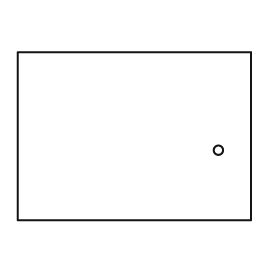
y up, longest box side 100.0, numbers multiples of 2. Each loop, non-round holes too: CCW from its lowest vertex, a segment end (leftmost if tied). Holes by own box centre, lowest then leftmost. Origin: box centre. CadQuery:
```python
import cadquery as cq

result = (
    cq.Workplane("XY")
    .moveTo(-50.0, -36.0)
    .lineTo(50.0, -36.0)
    .lineTo(50.0, 36.0)
    .lineTo(-50.0, 36.0)
    .close()
    .moveTo(36.0, -6.0)
    .circle(2.0)
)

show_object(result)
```